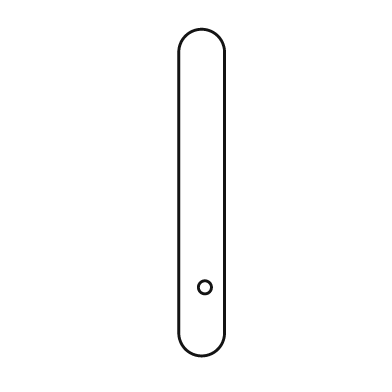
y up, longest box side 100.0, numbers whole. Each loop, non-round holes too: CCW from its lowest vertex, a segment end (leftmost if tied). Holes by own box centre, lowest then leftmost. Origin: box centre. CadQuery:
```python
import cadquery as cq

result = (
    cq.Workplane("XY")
    .moveTo(-7.0, -43.0)
    .threePointArc((0.0, -50.0), (7.0, -43.0))
    .lineTo(7.0, 43.0)
    .threePointArc((0.0, 50.0), (-7.0, 43.0))
    .close()
    .moveTo(1.0, -29.0)
    .circle(2.0)
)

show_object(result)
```